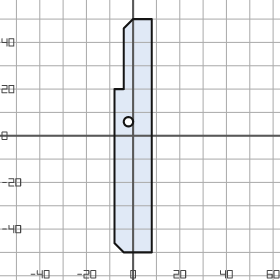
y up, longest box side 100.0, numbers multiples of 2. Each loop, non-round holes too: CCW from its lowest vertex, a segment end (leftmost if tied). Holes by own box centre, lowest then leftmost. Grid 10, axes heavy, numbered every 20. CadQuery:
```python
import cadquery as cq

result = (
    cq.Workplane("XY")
    .moveTo(-4.0, -50.0)
    .lineTo(8.0, -50.0)
    .lineTo(8.0, 50.0)
    .lineTo(0.0, 50.0)
    .lineTo(-4.0, 46.0)
    .lineTo(-4.0, 20.0)
    .lineTo(-8.0, 20.0)
    .lineTo(-8.0, -46.0)
    .close()
    .moveTo(-2.0, 6.0)
    .circle(2.0)
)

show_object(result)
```